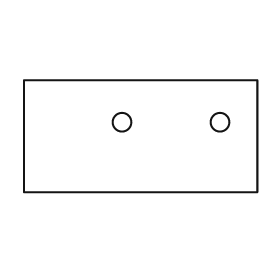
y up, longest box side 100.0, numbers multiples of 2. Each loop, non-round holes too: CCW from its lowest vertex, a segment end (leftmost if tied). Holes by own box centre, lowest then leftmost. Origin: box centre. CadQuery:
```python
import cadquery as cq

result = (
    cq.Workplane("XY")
    .moveTo(-50.0, -24.0)
    .lineTo(50.0, -24.0)
    .lineTo(50.0, 24.0)
    .lineTo(-50.0, 24.0)
    .close()
    .moveTo(-8.0, 6.0)
    .circle(4.0)
    .moveTo(34.0, 6.0)
    .circle(4.0)
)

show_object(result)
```